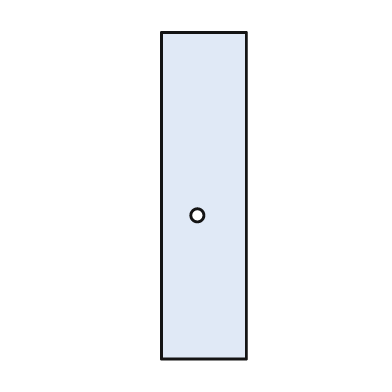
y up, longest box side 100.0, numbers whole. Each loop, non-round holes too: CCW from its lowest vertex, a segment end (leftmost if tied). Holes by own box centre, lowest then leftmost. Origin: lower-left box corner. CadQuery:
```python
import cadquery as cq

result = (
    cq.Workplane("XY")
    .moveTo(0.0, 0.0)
    .lineTo(26.0, 0.0)
    .lineTo(26.0, 100.0)
    .lineTo(0.0, 100.0)
    .close()
    .moveTo(11.0, 44.0)
    .circle(2.0)
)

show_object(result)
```